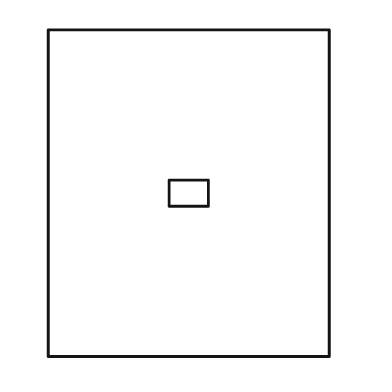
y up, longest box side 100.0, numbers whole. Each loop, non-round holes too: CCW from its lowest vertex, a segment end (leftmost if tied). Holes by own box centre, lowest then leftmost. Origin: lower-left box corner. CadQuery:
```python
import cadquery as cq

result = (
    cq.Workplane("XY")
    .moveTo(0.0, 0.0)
    .lineTo(86.0, 0.0)
    .lineTo(86.0, 100.0)
    .lineTo(0.0, 100.0)
    .close()
    .moveTo(37.0, 46.0)
    .lineTo(49.0, 46.0)
    .lineTo(49.0, 54.0)
    .lineTo(37.0, 54.0)
    .close()
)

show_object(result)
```